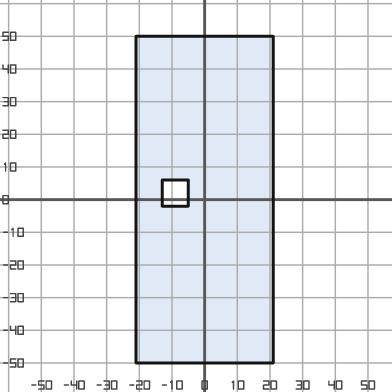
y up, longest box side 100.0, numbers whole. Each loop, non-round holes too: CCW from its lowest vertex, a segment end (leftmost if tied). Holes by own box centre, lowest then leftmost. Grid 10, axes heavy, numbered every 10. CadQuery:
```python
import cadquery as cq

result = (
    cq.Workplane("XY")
    .moveTo(-21.0, -50.0)
    .lineTo(21.0, -50.0)
    .lineTo(21.0, 50.0)
    .lineTo(-21.0, 50.0)
    .close()
    .moveTo(-13.0, -2.0)
    .lineTo(-5.0, -2.0)
    .lineTo(-5.0, 6.0)
    .lineTo(-13.0, 6.0)
    .close()
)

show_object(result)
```